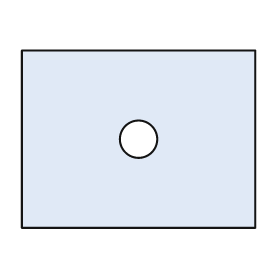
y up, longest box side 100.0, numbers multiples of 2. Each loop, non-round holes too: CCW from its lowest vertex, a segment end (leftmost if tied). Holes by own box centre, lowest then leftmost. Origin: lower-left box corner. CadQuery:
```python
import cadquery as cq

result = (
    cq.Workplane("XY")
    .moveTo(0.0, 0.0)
    .lineTo(100.0, 0.0)
    .lineTo(100.0, 76.0)
    .lineTo(0.0, 76.0)
    .close()
    .moveTo(50.0, 38.0)
    .circle(8.0)
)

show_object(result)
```